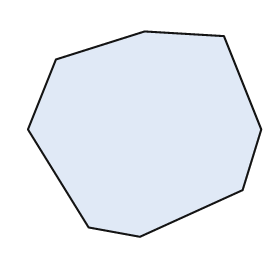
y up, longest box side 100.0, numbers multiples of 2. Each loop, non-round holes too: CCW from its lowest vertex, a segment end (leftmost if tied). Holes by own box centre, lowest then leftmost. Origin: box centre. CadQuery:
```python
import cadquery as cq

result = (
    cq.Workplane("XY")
    .moveTo(-2.0, -44.0)
    .lineTo(42.0, -24.0)
    .lineTo(50.0, 2.0)
    .lineTo(34.0, 42.0)
    .lineTo(0.0, 44.0)
    .lineTo(-38.0, 32.0)
    .lineTo(-50.0, 2.0)
    .lineTo(-24.0, -40.0)
    .close()
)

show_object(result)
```